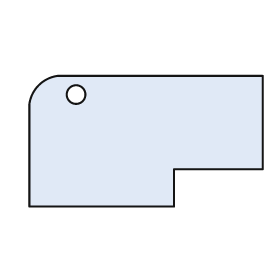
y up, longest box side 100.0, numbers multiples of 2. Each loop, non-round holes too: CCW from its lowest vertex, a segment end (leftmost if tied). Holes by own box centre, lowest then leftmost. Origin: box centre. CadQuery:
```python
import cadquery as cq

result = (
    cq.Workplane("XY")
    .moveTo(-50.0, -28.0)
    .lineTo(12.0, -28.0)
    .lineTo(12.0, -12.0)
    .lineTo(50.0, -12.0)
    .lineTo(50.0, 28.0)
    .lineTo(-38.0, 28.0)
    .threePointArc((-46.0, 24.0), (-50.0, 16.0))
    .close()
    .moveTo(-30.0, 20.0)
    .circle(4.0)
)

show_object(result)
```